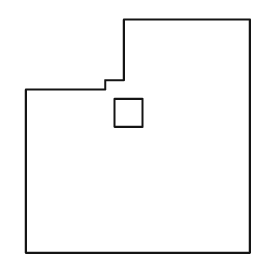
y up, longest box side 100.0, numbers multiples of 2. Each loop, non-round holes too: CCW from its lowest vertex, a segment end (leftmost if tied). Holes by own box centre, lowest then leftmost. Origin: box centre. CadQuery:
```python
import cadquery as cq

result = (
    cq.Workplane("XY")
    .moveTo(-48.0, -50.0)
    .lineTo(48.0, -50.0)
    .lineTo(48.0, 50.0)
    .lineTo(-6.0, 50.0)
    .lineTo(-6.0, 24.0)
    .lineTo(-14.0, 24.0)
    .lineTo(-14.0, 20.0)
    .lineTo(-48.0, 20.0)
    .close()
    .moveTo(-10.0, 4.0)
    .lineTo(2.0, 4.0)
    .lineTo(2.0, 16.0)
    .lineTo(-10.0, 16.0)
    .close()
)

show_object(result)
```